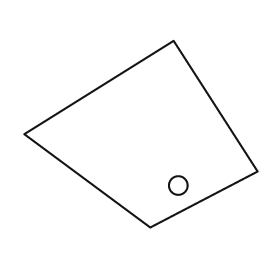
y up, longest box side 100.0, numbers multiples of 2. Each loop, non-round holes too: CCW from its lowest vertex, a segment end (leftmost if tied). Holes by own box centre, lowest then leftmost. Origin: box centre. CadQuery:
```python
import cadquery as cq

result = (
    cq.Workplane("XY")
    .moveTo(4.0, -40.0)
    .lineTo(50.0, -16.0)
    .lineTo(14.0, 40.0)
    .lineTo(-50.0, 0.0)
    .close()
    .moveTo(16.0, -22.0)
    .circle(4.0)
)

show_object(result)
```